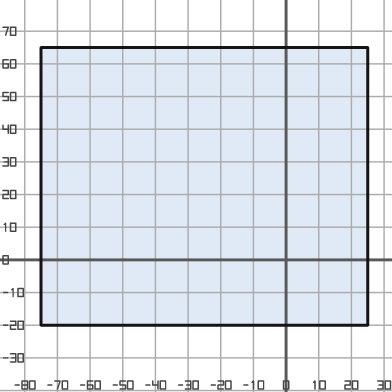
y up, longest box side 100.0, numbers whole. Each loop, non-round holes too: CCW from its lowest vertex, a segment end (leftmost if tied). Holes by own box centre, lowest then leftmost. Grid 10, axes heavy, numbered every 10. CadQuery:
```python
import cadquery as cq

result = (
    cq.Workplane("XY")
    .moveTo(-75.0, -20.0)
    .lineTo(25.0, -20.0)
    .lineTo(25.0, 65.0)
    .lineTo(-75.0, 65.0)
    .close()
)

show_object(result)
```